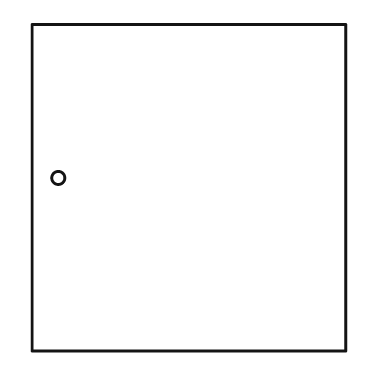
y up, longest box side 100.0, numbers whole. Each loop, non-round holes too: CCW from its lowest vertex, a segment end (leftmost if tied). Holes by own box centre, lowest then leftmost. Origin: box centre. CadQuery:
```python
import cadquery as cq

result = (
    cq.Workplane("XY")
    .moveTo(-48.0, -50.0)
    .lineTo(48.0, -50.0)
    .lineTo(48.0, 50.0)
    .lineTo(-48.0, 50.0)
    .close()
    .moveTo(-40.0, 3.0)
    .circle(2.0)
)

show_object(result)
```